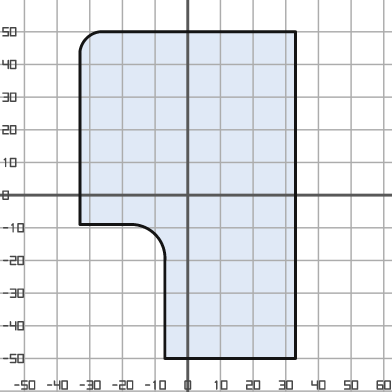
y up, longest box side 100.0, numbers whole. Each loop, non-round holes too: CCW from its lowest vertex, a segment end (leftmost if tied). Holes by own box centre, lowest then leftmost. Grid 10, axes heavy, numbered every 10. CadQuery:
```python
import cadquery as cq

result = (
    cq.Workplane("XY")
    .moveTo(-7.0, -50.0)
    .lineTo(33.0, -50.0)
    .lineTo(33.0, 50.0)
    .lineTo(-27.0, 50.0)
    .threePointArc((-31.0, 48.0), (-33.0, 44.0))
    .lineTo(-33.0, -9.0)
    .lineTo(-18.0, -9.0)
    .threePointArc((-10.0, -12.0), (-7.0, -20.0))
    .close()
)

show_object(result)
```